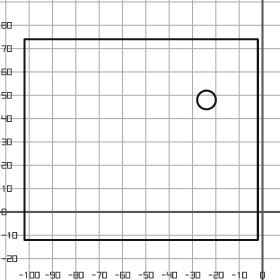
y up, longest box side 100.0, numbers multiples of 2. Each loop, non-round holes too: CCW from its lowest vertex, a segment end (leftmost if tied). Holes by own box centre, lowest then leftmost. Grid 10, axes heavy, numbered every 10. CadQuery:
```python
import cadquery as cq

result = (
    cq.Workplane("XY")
    .moveTo(-102.0, -12.0)
    .lineTo(-2.0, -12.0)
    .lineTo(-2.0, 74.0)
    .lineTo(-102.0, 74.0)
    .close()
    .moveTo(-24.0, 48.0)
    .circle(4.0)
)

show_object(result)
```